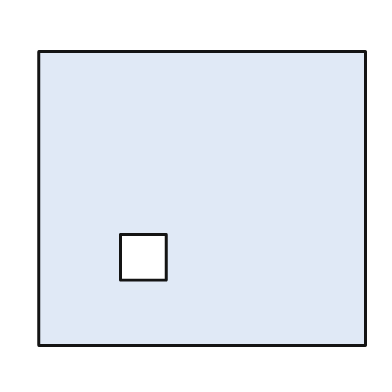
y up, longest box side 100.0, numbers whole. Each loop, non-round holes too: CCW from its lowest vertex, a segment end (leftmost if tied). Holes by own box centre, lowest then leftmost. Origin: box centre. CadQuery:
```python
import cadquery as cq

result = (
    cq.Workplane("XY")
    .moveTo(-50.0, -45.0)
    .lineTo(50.0, -45.0)
    .lineTo(50.0, 45.0)
    .lineTo(-50.0, 45.0)
    .close()
    .moveTo(-25.0, -25.0)
    .lineTo(-11.0, -25.0)
    .lineTo(-11.0, -11.0)
    .lineTo(-25.0, -11.0)
    .close()
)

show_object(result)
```